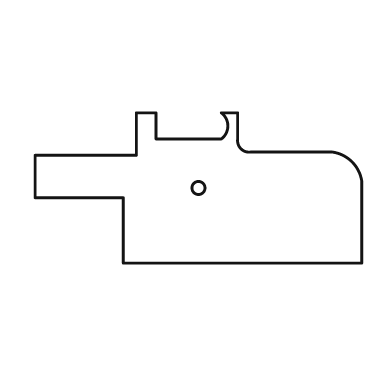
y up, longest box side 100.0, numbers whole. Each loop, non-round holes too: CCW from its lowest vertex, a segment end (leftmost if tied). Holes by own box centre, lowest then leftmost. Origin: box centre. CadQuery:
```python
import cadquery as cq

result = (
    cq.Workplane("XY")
    .moveTo(-23.0, -23.0)
    .lineTo(50.0, -23.0)
    .lineTo(50.0, 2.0)
    .threePointArc((47.0, 8.0), (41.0, 11.0))
    .lineTo(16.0, 11.0)
    .threePointArc((13.0, 12.0), (12.0, 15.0))
    .lineTo(12.0, 23.0)
    .lineTo(7.0, 23.0)
    .threePointArc((9.0, 19.0), (7.0, 15.0))
    .lineTo(-13.0, 15.0)
    .lineTo(-13.0, 23.0)
    .lineTo(-19.0, 23.0)
    .lineTo(-19.0, 10.0)
    .lineTo(-50.0, 10.0)
    .lineTo(-50.0, -3.0)
    .lineTo(-23.0, -3.0)
    .close()
    .moveTo(0.0, 0.0)
    .circle(2.0)
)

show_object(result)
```